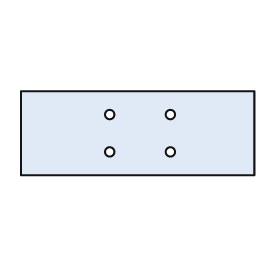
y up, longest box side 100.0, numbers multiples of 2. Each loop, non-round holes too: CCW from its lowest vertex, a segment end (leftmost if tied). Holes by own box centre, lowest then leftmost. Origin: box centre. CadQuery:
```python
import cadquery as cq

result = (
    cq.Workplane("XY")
    .moveTo(-50.0, -18.0)
    .lineTo(50.0, -18.0)
    .lineTo(50.0, 18.0)
    .lineTo(-50.0, 18.0)
    .close()
    .moveTo(-12.0, -8.0)
    .circle(2.0)
    .moveTo(14.0, -8.0)
    .circle(2.0)
    .moveTo(-12.0, 8.0)
    .circle(2.0)
    .moveTo(14.0, 8.0)
    .circle(2.0)
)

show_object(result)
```